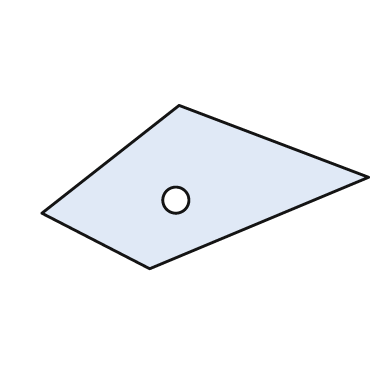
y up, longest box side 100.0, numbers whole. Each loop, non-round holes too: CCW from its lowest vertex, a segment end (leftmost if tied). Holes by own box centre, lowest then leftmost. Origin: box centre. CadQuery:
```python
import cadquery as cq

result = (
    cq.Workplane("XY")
    .moveTo(-17.0, -25.0)
    .lineTo(50.0, 3.0)
    .lineTo(-8.0, 25.0)
    .lineTo(-50.0, -8.0)
    .close()
    .moveTo(-9.0, -4.0)
    .circle(4.0)
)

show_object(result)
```